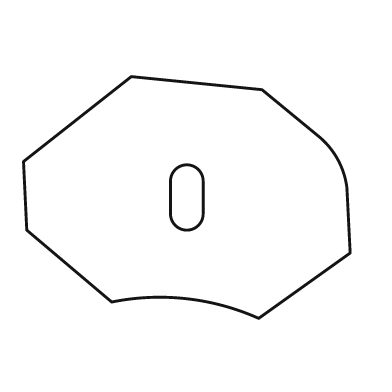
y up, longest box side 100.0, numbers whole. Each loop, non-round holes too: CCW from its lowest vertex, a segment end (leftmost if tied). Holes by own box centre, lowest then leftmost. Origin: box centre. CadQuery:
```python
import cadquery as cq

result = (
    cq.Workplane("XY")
    .moveTo(22.0, -37.0)
    .lineTo(50.0, -17.0)
    .lineTo(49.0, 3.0)
    .threePointArc((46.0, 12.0), (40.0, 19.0))
    .lineTo(23.0, 33.0)
    .lineTo(-17.0, 37.0)
    .lineTo(-50.0, 11.0)
    .lineTo(-49.0, -10.0)
    .lineTo(-23.0, -32.0)
    .threePointArc((0.0, -31.0), (22.0, -37.0))
    .close()
    .moveTo(-5.0, -5.0)
    .threePointArc((0.0, -10.0), (5.0, -5.0))
    .lineTo(5.0, 5.0)
    .threePointArc((0.0, 10.0), (-5.0, 5.0))
    .close()
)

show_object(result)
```